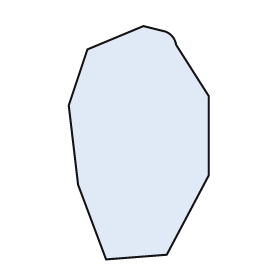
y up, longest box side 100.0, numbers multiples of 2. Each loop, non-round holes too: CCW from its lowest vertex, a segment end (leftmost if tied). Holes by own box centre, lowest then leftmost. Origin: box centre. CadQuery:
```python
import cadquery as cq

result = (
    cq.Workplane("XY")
    .moveTo(-14.0, -50.0)
    .lineTo(12.0, -48.0)
    .lineTo(30.0, -14.0)
    .lineTo(30.0, 20.0)
    .lineTo(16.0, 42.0)
    .threePointArc((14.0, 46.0), (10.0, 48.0))
    .lineTo(2.0, 50.0)
    .lineTo(-22.0, 40.0)
    .lineTo(-30.0, 16.0)
    .lineTo(-26.0, -18.0)
    .close()
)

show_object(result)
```